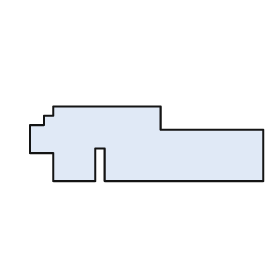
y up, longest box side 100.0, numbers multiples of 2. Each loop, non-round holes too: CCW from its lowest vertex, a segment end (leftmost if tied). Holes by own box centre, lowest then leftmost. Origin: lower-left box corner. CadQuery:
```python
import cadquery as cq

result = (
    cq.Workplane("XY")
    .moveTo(10.0, 0.0)
    .lineTo(28.0, 0.0)
    .lineTo(28.0, 14.0)
    .lineTo(32.0, 14.0)
    .lineTo(32.0, 0.0)
    .lineTo(100.0, 0.0)
    .lineTo(100.0, 22.0)
    .lineTo(56.0, 22.0)
    .lineTo(56.0, 32.0)
    .lineTo(10.0, 32.0)
    .lineTo(10.0, 28.0)
    .lineTo(6.0, 28.0)
    .lineTo(6.0, 24.0)
    .lineTo(0.0, 24.0)
    .lineTo(0.0, 12.0)
    .lineTo(10.0, 12.0)
    .close()
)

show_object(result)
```